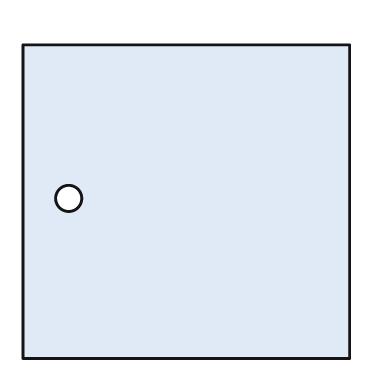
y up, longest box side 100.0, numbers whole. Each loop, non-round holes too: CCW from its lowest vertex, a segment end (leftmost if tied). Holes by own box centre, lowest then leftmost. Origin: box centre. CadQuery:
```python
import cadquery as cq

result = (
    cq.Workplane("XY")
    .moveTo(-50.0, -48.0)
    .lineTo(50.0, -48.0)
    .lineTo(50.0, 48.0)
    .lineTo(-50.0, 48.0)
    .close()
    .moveTo(-36.0, 1.0)
    .circle(4.0)
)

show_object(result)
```